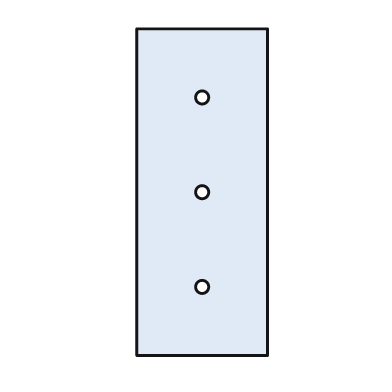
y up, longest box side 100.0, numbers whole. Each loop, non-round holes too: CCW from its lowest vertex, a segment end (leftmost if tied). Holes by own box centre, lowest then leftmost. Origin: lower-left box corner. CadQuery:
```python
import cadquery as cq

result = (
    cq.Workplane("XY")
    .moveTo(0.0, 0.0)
    .lineTo(40.0, 0.0)
    .lineTo(40.0, 100.0)
    .lineTo(0.0, 100.0)
    .close()
    .moveTo(20.0, 21.0)
    .circle(2.0)
    .moveTo(20.0, 50.0)
    .circle(2.0)
    .moveTo(20.0, 79.0)
    .circle(2.0)
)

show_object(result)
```